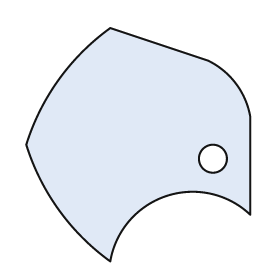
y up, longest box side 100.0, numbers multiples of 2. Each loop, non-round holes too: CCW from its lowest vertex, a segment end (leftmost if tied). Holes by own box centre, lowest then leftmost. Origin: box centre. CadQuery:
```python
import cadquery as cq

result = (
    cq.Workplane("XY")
    .moveTo(-12.0, -50.0)
    .threePointArc((12.0, -22.0), (48.0, -30.0))
    .lineTo(48.0, 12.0)
    .threePointArc((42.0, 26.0), (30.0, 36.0))
    .lineTo(-12.0, 50.0)
    .threePointArc((-34.0, 28.0), (-48.0, 0.0))
    .threePointArc((-34.0, -28.0), (-12.0, -50.0))
    .close()
    .moveTo(32.0, -6.0)
    .circle(6.0)
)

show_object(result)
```